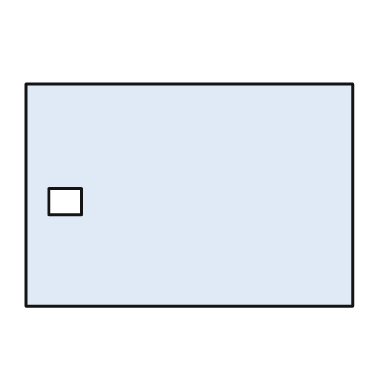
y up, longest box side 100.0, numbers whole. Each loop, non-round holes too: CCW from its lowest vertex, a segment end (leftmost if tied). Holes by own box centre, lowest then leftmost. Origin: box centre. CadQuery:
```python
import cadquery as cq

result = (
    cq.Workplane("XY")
    .moveTo(-50.0, -34.0)
    .lineTo(50.0, -34.0)
    .lineTo(50.0, 34.0)
    .lineTo(-50.0, 34.0)
    .close()
    .moveTo(-43.0, -6.0)
    .lineTo(-33.0, -6.0)
    .lineTo(-33.0, 2.0)
    .lineTo(-43.0, 2.0)
    .close()
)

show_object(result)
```